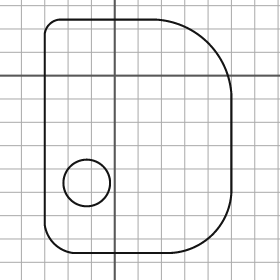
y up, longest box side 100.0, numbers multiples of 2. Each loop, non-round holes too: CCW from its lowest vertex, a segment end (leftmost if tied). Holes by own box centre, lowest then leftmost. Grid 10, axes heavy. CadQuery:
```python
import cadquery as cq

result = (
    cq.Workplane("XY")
    .moveTo(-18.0, -76.0)
    .lineTo(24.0, -76.0)
    .threePointArc((42.0, -68.0), (50.0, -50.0))
    .lineTo(50.0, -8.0)
    .threePointArc((40.0, 14.0), (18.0, 24.0))
    .lineTo(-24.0, 24.0)
    .threePointArc((-28.0, 22.0), (-30.0, 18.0))
    .lineTo(-30.0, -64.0)
    .threePointArc((-26.0, -72.0), (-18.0, -76.0))
    .close()
    .moveTo(-12.0, -46.0)
    .circle(10.0)
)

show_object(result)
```